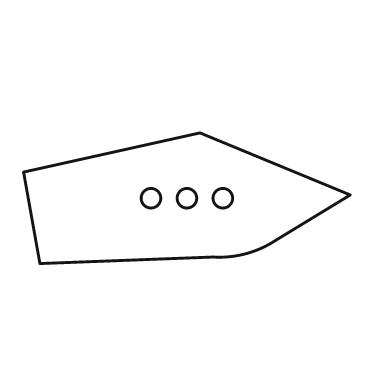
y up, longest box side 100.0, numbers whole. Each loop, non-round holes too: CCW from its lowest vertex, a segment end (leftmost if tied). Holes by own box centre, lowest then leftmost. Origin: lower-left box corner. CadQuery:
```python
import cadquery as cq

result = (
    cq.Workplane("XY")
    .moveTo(5.0, 0.0)
    .lineTo(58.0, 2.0)
    .threePointArc((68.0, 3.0), (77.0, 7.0))
    .lineTo(100.0, 21.0)
    .lineTo(54.0, 40.0)
    .lineTo(0.0, 28.0)
    .close()
    .moveTo(39.0, 20.0)
    .circle(3.0)
    .moveTo(50.0, 20.0)
    .circle(3.0)
    .moveTo(61.0, 20.0)
    .circle(3.0)
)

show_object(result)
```